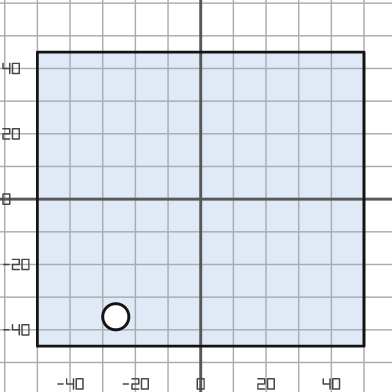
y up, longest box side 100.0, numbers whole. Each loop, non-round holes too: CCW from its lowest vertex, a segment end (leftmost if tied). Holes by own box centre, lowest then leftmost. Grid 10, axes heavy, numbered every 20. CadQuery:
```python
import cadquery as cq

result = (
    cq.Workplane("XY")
    .moveTo(-50.0, -45.0)
    .lineTo(50.0, -45.0)
    .lineTo(50.0, 45.0)
    .lineTo(-50.0, 45.0)
    .close()
    .moveTo(-26.0, -36.0)
    .circle(4.0)
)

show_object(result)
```